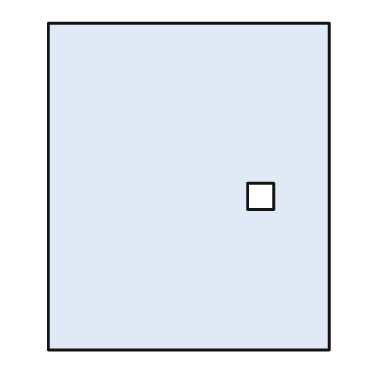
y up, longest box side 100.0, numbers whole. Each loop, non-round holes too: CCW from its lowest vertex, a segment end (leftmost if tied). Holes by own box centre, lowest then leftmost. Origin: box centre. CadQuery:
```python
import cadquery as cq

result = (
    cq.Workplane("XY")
    .moveTo(-43.0, -50.0)
    .lineTo(43.0, -50.0)
    .lineTo(43.0, 50.0)
    .lineTo(-43.0, 50.0)
    .close()
    .moveTo(18.0, -7.0)
    .lineTo(26.0, -7.0)
    .lineTo(26.0, 1.0)
    .lineTo(18.0, 1.0)
    .close()
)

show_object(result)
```